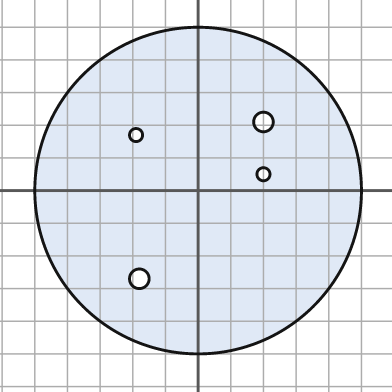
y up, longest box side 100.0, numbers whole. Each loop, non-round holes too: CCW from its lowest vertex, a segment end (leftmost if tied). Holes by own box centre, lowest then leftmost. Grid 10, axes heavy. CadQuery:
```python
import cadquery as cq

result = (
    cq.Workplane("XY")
    .moveTo(0.0, 0.0)
    .circle(50.0)
    .moveTo(-18.0, -27.0)
    .circle(3.0)
    .moveTo(20.0, 5.0)
    .circle(2.0)
    .moveTo(-19.0, 17.0)
    .circle(2.0)
    .moveTo(20.0, 21.0)
    .circle(3.0)
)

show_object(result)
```